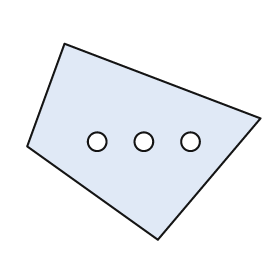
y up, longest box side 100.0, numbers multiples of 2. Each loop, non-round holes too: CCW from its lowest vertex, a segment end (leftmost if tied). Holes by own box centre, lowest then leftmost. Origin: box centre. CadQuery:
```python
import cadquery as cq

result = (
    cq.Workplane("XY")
    .moveTo(6.0, -42.0)
    .lineTo(50.0, 10.0)
    .lineTo(-34.0, 42.0)
    .lineTo(-50.0, -2.0)
    .close()
    .moveTo(-20.0, 0.0)
    .circle(4.0)
    .moveTo(0.0, 0.0)
    .circle(4.0)
    .moveTo(20.0, 0.0)
    .circle(4.0)
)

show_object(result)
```